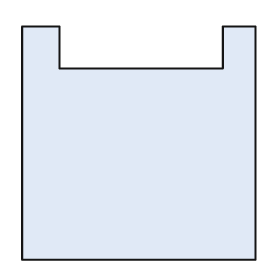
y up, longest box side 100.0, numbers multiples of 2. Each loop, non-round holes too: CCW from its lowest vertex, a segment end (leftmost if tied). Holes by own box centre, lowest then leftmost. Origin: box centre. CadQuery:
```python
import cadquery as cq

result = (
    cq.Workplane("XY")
    .moveTo(-50.0, -50.0)
    .lineTo(50.0, -50.0)
    .lineTo(50.0, 50.0)
    .lineTo(36.0, 50.0)
    .lineTo(36.0, 32.0)
    .lineTo(-34.0, 32.0)
    .lineTo(-34.0, 50.0)
    .lineTo(-50.0, 50.0)
    .close()
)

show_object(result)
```